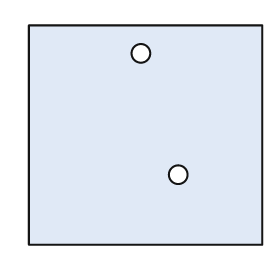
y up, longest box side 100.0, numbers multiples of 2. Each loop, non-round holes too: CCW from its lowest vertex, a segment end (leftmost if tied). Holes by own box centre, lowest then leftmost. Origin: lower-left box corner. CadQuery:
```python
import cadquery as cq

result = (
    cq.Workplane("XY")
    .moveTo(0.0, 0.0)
    .lineTo(100.0, 0.0)
    .lineTo(100.0, 94.0)
    .lineTo(0.0, 94.0)
    .close()
    .moveTo(64.0, 30.0)
    .circle(4.0)
    .moveTo(48.0, 82.0)
    .circle(4.0)
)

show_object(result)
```